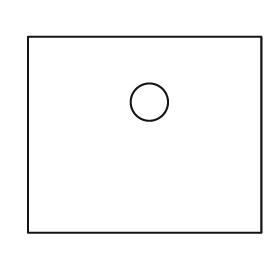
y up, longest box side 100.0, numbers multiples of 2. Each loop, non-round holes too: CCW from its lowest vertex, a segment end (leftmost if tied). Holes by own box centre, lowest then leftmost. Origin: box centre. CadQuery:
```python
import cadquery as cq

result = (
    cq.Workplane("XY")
    .moveTo(-50.0, -42.0)
    .lineTo(50.0, -42.0)
    .lineTo(50.0, 42.0)
    .lineTo(-50.0, 42.0)
    .close()
    .moveTo(2.0, 14.0)
    .circle(8.0)
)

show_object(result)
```